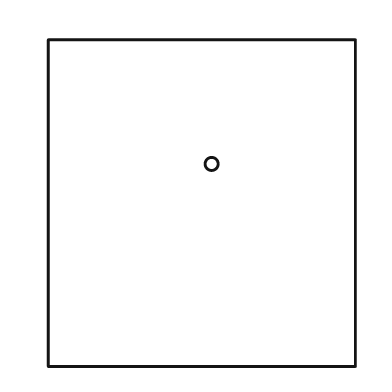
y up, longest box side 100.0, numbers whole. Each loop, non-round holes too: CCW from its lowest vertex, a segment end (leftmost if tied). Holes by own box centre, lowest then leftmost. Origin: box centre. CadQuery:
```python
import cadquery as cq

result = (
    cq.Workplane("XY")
    .moveTo(-47.0, -50.0)
    .lineTo(47.0, -50.0)
    .lineTo(47.0, 50.0)
    .lineTo(-47.0, 50.0)
    .close()
    .moveTo(3.0, 12.0)
    .circle(2.0)
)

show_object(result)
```